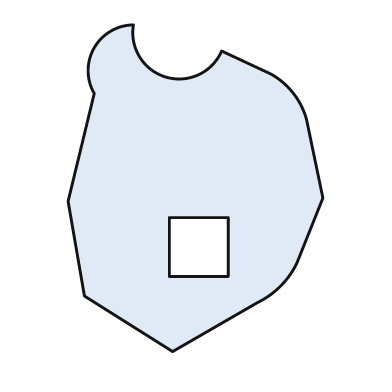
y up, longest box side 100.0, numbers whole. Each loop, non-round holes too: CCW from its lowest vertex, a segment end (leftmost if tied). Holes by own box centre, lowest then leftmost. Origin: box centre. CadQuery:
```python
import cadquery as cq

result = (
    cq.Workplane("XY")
    .moveTo(-7.0, -50.0)
    .lineTo(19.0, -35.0)
    .threePointArc((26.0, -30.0), (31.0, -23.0))
    .lineTo(39.0, -3.0)
    .lineTo(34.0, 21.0)
    .threePointArc((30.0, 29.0), (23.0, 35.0))
    .lineTo(8.0, 42.0)
    .threePointArc((-9.0, 34.0), (-19.0, 50.0))
    .threePointArc((-31.0, 43.0), (-31.0, 29.0))
    .lineTo(-39.0, -4.0)
    .lineTo(-34.0, -33.0)
    .close()
    .moveTo(-8.0, -27.0)
    .lineTo(10.0, -27.0)
    .lineTo(10.0, -9.0)
    .lineTo(-8.0, -9.0)
    .close()
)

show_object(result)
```